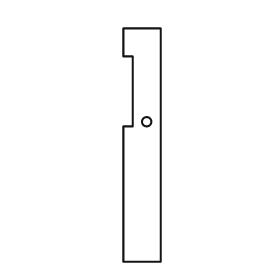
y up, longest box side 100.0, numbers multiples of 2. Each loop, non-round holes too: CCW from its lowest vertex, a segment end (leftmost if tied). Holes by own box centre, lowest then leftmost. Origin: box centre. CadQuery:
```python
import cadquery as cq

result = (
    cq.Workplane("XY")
    .moveTo(-8.0, -50.0)
    .lineTo(8.0, -50.0)
    .lineTo(8.0, 50.0)
    .lineTo(-8.0, 50.0)
    .lineTo(-8.0, 38.0)
    .lineTo(-4.0, 38.0)
    .lineTo(-4.0, 8.0)
    .lineTo(-8.0, 8.0)
    .close()
    .moveTo(2.0, 10.0)
    .circle(2.0)
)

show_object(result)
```